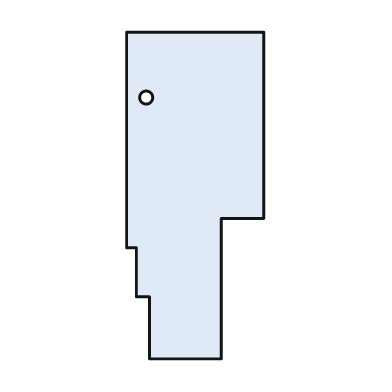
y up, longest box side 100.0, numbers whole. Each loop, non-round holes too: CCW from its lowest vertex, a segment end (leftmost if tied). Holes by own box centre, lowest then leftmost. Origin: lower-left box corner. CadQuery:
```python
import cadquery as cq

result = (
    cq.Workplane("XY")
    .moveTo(7.0, 0.0)
    .lineTo(29.0, 0.0)
    .lineTo(29.0, 43.0)
    .lineTo(42.0, 43.0)
    .lineTo(42.0, 100.0)
    .lineTo(0.0, 100.0)
    .lineTo(0.0, 34.0)
    .lineTo(3.0, 34.0)
    .lineTo(3.0, 19.0)
    .lineTo(7.0, 19.0)
    .close()
    .moveTo(6.0, 80.0)
    .circle(2.0)
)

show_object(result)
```